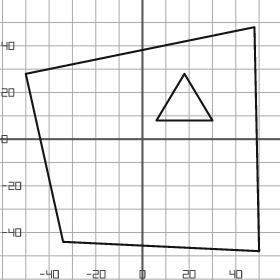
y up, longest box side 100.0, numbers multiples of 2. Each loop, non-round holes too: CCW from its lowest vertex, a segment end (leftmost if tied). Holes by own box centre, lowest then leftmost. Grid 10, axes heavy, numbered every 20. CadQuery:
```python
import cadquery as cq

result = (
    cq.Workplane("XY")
    .moveTo(50.0, -48.0)
    .lineTo(48.0, 48.0)
    .lineTo(-50.0, 28.0)
    .lineTo(-34.0, -44.0)
    .close()
    .moveTo(6.0, 8.0)
    .lineTo(30.0, 8.0)
    .lineTo(18.0, 28.0)
    .close()
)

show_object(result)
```